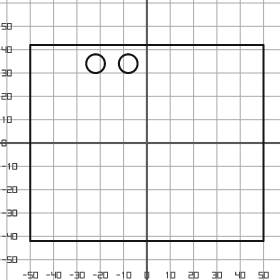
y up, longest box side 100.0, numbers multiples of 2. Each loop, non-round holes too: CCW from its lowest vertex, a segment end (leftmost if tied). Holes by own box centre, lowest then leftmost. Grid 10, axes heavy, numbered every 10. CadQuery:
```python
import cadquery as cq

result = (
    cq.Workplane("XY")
    .moveTo(-50.0, -42.0)
    .lineTo(50.0, -42.0)
    .lineTo(50.0, 42.0)
    .lineTo(-50.0, 42.0)
    .close()
    .moveTo(-22.0, 34.0)
    .circle(4.0)
    .moveTo(-8.0, 34.0)
    .circle(4.0)
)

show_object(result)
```